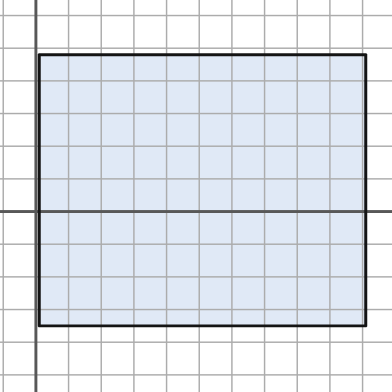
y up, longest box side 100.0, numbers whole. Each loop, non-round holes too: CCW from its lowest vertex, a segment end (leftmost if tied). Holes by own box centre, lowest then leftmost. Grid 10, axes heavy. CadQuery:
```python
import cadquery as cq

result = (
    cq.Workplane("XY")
    .moveTo(1.0, -35.0)
    .lineTo(101.0, -35.0)
    .lineTo(101.0, 48.0)
    .lineTo(1.0, 48.0)
    .close()
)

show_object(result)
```